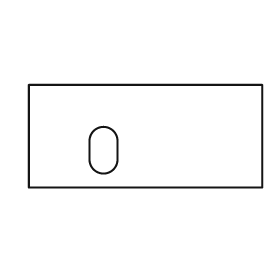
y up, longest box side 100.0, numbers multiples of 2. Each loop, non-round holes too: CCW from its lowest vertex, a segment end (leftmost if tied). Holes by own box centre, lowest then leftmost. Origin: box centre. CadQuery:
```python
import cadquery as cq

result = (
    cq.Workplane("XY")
    .moveTo(-50.0, -22.0)
    .lineTo(50.0, -22.0)
    .lineTo(50.0, 22.0)
    .lineTo(-50.0, 22.0)
    .close()
    .moveTo(-24.0, -10.0)
    .threePointArc((-18.0, -16.0), (-12.0, -10.0))
    .lineTo(-12.0, -2.0)
    .threePointArc((-18.0, 4.0), (-24.0, -2.0))
    .close()
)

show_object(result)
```